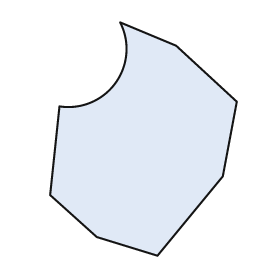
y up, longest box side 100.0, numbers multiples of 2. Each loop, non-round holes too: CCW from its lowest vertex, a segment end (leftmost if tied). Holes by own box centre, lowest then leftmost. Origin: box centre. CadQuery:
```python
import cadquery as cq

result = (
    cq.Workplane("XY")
    .moveTo(6.0, -50.0)
    .lineTo(34.0, -16.0)
    .lineTo(40.0, 16.0)
    .lineTo(14.0, 40.0)
    .lineTo(-10.0, 50.0)
    .threePointArc((-12.0, 24.0), (-36.0, 14.0))
    .lineTo(-40.0, -24.0)
    .lineTo(-20.0, -42.0)
    .close()
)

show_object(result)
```